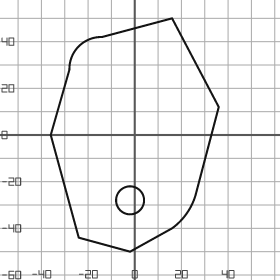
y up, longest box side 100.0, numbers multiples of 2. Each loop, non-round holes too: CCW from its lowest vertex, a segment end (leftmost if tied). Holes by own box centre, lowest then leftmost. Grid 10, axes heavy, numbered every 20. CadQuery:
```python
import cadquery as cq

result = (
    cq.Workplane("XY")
    .moveTo(-2.0, -50.0)
    .lineTo(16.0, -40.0)
    .threePointArc((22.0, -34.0), (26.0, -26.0))
    .lineTo(36.0, 12.0)
    .lineTo(16.0, 50.0)
    .lineTo(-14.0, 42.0)
    .threePointArc((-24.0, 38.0), (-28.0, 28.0))
    .lineTo(-36.0, 0.0)
    .lineTo(-24.0, -44.0)
    .close()
    .moveTo(-2.0, -28.0)
    .circle(6.0)
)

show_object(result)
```